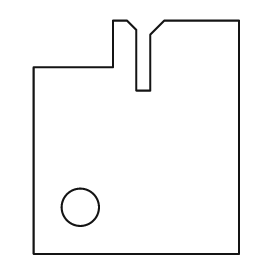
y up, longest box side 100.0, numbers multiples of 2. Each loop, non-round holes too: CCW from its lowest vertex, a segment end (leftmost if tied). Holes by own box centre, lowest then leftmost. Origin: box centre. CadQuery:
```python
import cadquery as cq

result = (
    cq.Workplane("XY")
    .moveTo(-44.0, -50.0)
    .lineTo(44.0, -50.0)
    .lineTo(44.0, 50.0)
    .lineTo(12.0, 50.0)
    .lineTo(6.0, 44.0)
    .lineTo(6.0, 20.0)
    .lineTo(0.0, 20.0)
    .lineTo(0.0, 46.0)
    .lineTo(-4.0, 50.0)
    .lineTo(-10.0, 50.0)
    .lineTo(-10.0, 30.0)
    .lineTo(-44.0, 30.0)
    .close()
    .moveTo(-24.0, -30.0)
    .circle(8.0)
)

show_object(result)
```